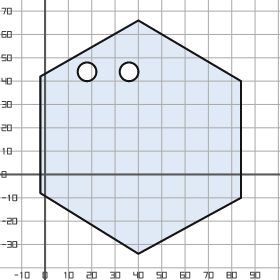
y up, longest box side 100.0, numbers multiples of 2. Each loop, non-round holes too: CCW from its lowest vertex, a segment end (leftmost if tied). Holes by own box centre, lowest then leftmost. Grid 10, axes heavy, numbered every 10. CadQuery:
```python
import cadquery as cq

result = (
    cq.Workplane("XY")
    .moveTo(40.0, -34.0)
    .lineTo(84.0, -10.0)
    .lineTo(84.0, 40.0)
    .lineTo(40.0, 66.0)
    .lineTo(-2.0, 42.0)
    .lineTo(-2.0, -8.0)
    .close()
    .moveTo(18.0, 44.0)
    .circle(4.0)
    .moveTo(36.0, 44.0)
    .circle(4.0)
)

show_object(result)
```